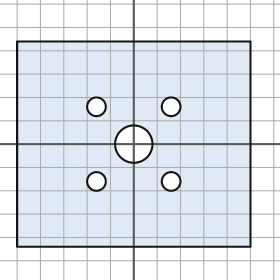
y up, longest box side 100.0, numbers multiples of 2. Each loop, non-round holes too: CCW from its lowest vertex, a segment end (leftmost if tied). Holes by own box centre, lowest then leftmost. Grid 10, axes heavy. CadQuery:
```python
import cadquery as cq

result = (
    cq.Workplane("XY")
    .moveTo(-50.0, -44.0)
    .lineTo(50.0, -44.0)
    .lineTo(50.0, 44.0)
    .lineTo(-50.0, 44.0)
    .close()
    .moveTo(-16.0, -16.0)
    .circle(4.0)
    .moveTo(16.0, -16.0)
    .circle(4.0)
    .moveTo(0.0, 0.0)
    .circle(8.0)
    .moveTo(-16.0, 16.0)
    .circle(4.0)
    .moveTo(16.0, 16.0)
    .circle(4.0)
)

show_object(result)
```